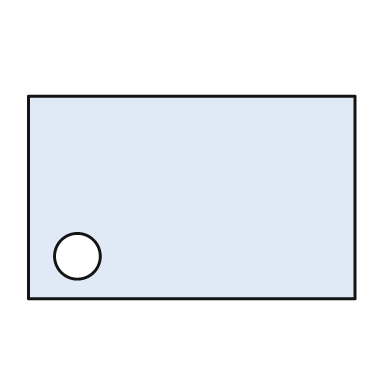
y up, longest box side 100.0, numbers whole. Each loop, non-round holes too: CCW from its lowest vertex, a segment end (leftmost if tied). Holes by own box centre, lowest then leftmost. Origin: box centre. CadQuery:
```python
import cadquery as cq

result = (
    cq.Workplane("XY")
    .moveTo(-50.0, -31.0)
    .lineTo(50.0, -31.0)
    .lineTo(50.0, 31.0)
    .lineTo(-50.0, 31.0)
    .close()
    .moveTo(-35.0, -18.0)
    .circle(7.0)
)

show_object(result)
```